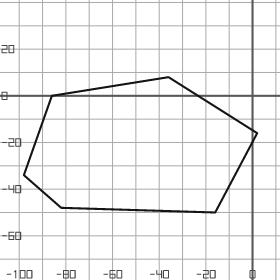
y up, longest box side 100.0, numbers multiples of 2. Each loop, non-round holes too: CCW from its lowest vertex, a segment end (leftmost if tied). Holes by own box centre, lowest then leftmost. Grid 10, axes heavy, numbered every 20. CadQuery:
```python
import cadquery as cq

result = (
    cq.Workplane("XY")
    .moveTo(-16.0, -50.0)
    .lineTo(2.0, -16.0)
    .lineTo(-36.0, 8.0)
    .lineTo(-86.0, 0.0)
    .lineTo(-98.0, -34.0)
    .lineTo(-82.0, -48.0)
    .close()
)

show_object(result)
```